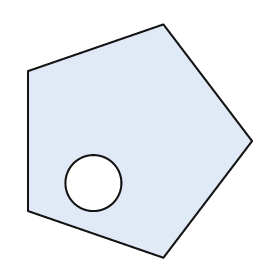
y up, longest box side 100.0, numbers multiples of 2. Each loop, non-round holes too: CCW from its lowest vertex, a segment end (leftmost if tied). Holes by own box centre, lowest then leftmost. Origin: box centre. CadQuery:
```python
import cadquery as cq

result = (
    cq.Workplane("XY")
    .moveTo(10.0, -50.0)
    .lineTo(48.0, 0.0)
    .lineTo(10.0, 50.0)
    .lineTo(-48.0, 30.0)
    .lineTo(-48.0, -30.0)
    .close()
    .moveTo(-20.0, -18.0)
    .circle(12.0)
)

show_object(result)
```